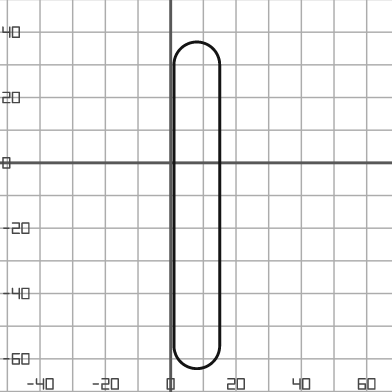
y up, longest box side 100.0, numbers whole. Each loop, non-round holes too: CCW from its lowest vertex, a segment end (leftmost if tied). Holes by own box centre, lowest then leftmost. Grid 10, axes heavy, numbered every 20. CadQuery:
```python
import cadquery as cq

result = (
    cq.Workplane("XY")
    .moveTo(1.0, -56.0)
    .threePointArc((8.0, -63.0), (15.0, -56.0))
    .lineTo(15.0, 30.0)
    .threePointArc((8.0, 37.0), (1.0, 30.0))
    .close()
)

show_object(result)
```